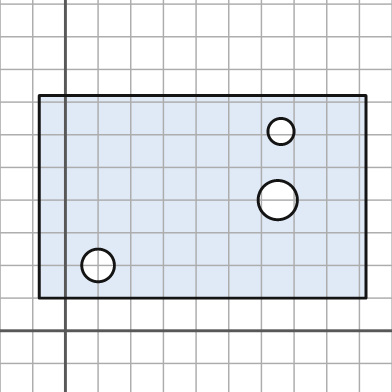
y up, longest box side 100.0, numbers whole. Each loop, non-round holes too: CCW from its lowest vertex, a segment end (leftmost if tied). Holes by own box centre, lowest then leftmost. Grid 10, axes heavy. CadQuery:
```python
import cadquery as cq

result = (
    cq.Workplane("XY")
    .moveTo(-8.0, 10.0)
    .lineTo(92.0, 10.0)
    .lineTo(92.0, 72.0)
    .lineTo(-8.0, 72.0)
    .close()
    .moveTo(10.0, 20.0)
    .circle(5.0)
    .moveTo(65.0, 40.0)
    .circle(6.0)
    .moveTo(66.0, 61.0)
    .circle(4.0)
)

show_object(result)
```